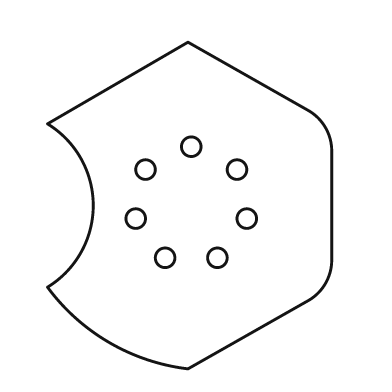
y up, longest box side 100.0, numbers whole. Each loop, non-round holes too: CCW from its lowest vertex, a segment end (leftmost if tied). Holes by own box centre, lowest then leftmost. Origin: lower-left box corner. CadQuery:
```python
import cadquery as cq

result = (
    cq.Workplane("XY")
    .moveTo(43.0, 0.0)
    .lineTo(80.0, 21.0)
    .threePointArc((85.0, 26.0), (87.0, 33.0))
    .lineTo(87.0, 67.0)
    .threePointArc((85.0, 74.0), (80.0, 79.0))
    .lineTo(43.0, 100.0)
    .lineTo(0.0, 75.0)
    .threePointArc((14.0, 50.0), (0.0, 25.0))
    .threePointArc((19.0, 8.0), (43.0, 0.0))
    .close()
    .moveTo(36.0, 34.0)
    .circle(3.0)
    .moveTo(52.0, 34.0)
    .circle(3.0)
    .moveTo(27.0, 46.0)
    .circle(3.0)
    .moveTo(61.0, 46.0)
    .circle(3.0)
    .moveTo(30.0, 61.0)
    .circle(3.0)
    .moveTo(58.0, 61.0)
    .circle(3.0)
    .moveTo(44.0, 68.0)
    .circle(3.0)
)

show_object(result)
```